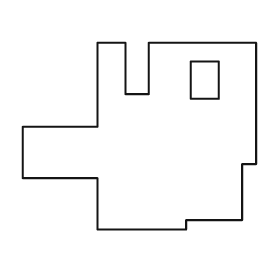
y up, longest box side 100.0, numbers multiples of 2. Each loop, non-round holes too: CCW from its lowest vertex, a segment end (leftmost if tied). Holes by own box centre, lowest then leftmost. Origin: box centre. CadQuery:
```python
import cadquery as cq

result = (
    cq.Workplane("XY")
    .moveTo(-18.0, -40.0)
    .lineTo(20.0, -40.0)
    .lineTo(20.0, -36.0)
    .lineTo(44.0, -36.0)
    .lineTo(44.0, -12.0)
    .lineTo(50.0, -12.0)
    .lineTo(50.0, 40.0)
    .lineTo(4.0, 40.0)
    .lineTo(4.0, 18.0)
    .lineTo(-6.0, 18.0)
    .lineTo(-6.0, 40.0)
    .lineTo(-18.0, 40.0)
    .lineTo(-18.0, 4.0)
    .lineTo(-50.0, 4.0)
    .lineTo(-50.0, -18.0)
    .lineTo(-18.0, -18.0)
    .close()
    .moveTo(22.0, 16.0)
    .lineTo(34.0, 16.0)
    .lineTo(34.0, 32.0)
    .lineTo(22.0, 32.0)
    .close()
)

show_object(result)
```